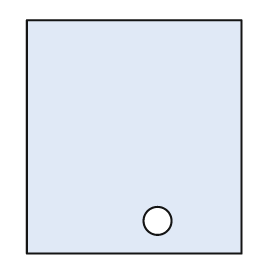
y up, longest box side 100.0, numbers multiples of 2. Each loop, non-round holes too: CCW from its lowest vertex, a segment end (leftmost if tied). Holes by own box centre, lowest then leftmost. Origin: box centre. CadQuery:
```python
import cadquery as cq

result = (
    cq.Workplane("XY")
    .moveTo(-46.0, -50.0)
    .lineTo(46.0, -50.0)
    .lineTo(46.0, 50.0)
    .lineTo(-46.0, 50.0)
    .close()
    .moveTo(10.0, -36.0)
    .circle(6.0)
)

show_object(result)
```